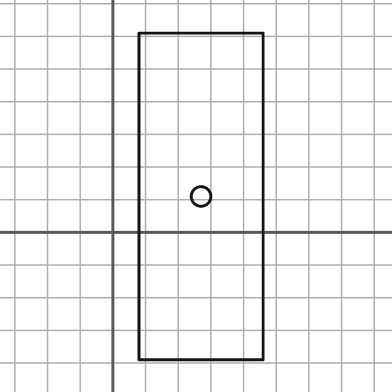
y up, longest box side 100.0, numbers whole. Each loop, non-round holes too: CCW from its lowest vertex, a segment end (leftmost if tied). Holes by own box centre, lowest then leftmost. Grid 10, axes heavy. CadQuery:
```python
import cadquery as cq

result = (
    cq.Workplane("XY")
    .moveTo(8.0, -39.0)
    .lineTo(46.0, -39.0)
    .lineTo(46.0, 61.0)
    .lineTo(8.0, 61.0)
    .close()
    .moveTo(27.0, 11.0)
    .circle(3.0)
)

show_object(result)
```